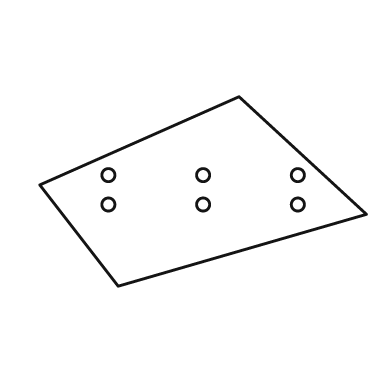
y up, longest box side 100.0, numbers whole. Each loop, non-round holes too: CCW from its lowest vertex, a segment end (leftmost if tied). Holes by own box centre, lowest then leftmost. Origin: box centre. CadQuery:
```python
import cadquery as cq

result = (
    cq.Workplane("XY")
    .moveTo(-26.0, -29.0)
    .lineTo(50.0, -7.0)
    .lineTo(11.0, 29.0)
    .lineTo(-50.0, 2.0)
    .close()
    .moveTo(-29.0, -4.0)
    .circle(2.0)
    .moveTo(0.0, -4.0)
    .circle(2.0)
    .moveTo(29.0, -4.0)
    .circle(2.0)
    .moveTo(-29.0, 5.0)
    .circle(2.0)
    .moveTo(0.0, 5.0)
    .circle(2.0)
    .moveTo(29.0, 5.0)
    .circle(2.0)
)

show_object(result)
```